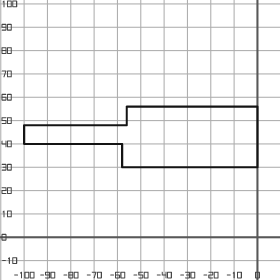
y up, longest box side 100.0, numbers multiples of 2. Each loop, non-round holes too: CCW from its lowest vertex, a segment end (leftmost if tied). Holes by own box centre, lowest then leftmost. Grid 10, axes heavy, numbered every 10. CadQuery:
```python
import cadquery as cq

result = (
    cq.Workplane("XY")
    .moveTo(-58.0, 30.0)
    .lineTo(0.0, 30.0)
    .lineTo(0.0, 56.0)
    .lineTo(-56.0, 56.0)
    .lineTo(-56.0, 48.0)
    .lineTo(-100.0, 48.0)
    .lineTo(-100.0, 40.0)
    .lineTo(-58.0, 40.0)
    .close()
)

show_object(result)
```